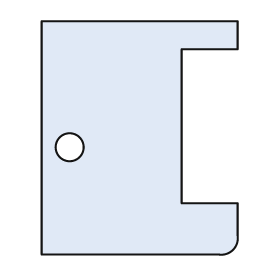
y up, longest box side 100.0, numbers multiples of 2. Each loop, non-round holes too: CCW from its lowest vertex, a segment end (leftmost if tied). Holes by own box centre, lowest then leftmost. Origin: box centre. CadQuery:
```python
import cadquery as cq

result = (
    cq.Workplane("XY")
    .moveTo(-42.0, -50.0)
    .lineTo(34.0, -50.0)
    .threePointArc((40.0, -48.0), (42.0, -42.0))
    .lineTo(42.0, -28.0)
    .lineTo(18.0, -28.0)
    .lineTo(18.0, 38.0)
    .lineTo(42.0, 38.0)
    .lineTo(42.0, 50.0)
    .lineTo(-42.0, 50.0)
    .close()
    .moveTo(-30.0, -4.0)
    .circle(6.0)
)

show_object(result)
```